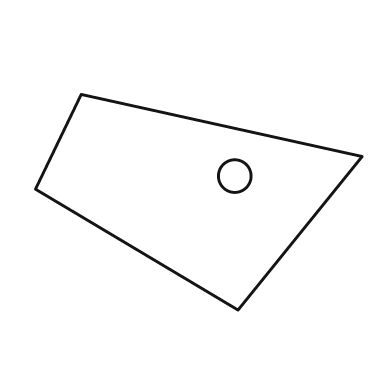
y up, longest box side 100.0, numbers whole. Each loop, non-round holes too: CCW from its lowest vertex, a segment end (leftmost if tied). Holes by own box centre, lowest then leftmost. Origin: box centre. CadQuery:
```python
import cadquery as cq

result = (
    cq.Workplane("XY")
    .moveTo(12.0, -33.0)
    .lineTo(50.0, 14.0)
    .lineTo(-36.0, 33.0)
    .lineTo(-50.0, 4.0)
    .close()
    .moveTo(11.0, 8.0)
    .circle(5.0)
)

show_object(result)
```